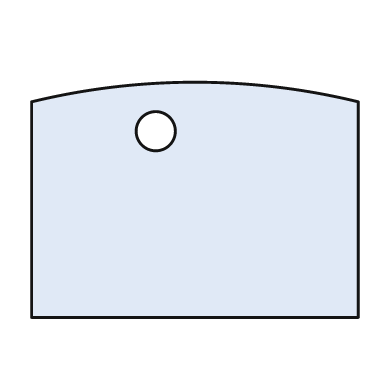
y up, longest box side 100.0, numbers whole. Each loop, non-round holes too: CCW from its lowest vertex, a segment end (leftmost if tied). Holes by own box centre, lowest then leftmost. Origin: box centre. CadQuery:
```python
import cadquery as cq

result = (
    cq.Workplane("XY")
    .moveTo(-50.0, -36.0)
    .lineTo(50.0, -36.0)
    .lineTo(50.0, 30.0)
    .threePointArc((0.0, 36.0), (-50.0, 30.0))
    .close()
    .moveTo(-12.0, 21.0)
    .circle(6.0)
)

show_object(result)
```